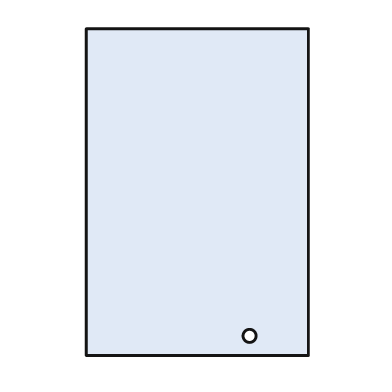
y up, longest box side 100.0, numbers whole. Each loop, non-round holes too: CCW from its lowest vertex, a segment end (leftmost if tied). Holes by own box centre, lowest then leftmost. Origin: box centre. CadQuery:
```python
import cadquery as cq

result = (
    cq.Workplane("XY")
    .moveTo(-34.0, -50.0)
    .lineTo(34.0, -50.0)
    .lineTo(34.0, 50.0)
    .lineTo(-34.0, 50.0)
    .close()
    .moveTo(16.0, -44.0)
    .circle(2.0)
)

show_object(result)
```